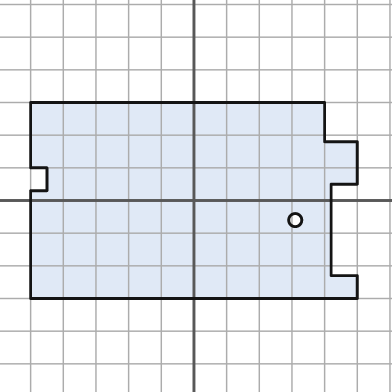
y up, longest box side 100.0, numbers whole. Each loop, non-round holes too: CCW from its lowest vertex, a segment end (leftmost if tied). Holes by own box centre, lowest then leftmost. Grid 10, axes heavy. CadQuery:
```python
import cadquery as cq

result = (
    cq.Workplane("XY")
    .moveTo(-50.0, -30.0)
    .lineTo(50.0, -30.0)
    .lineTo(50.0, -23.0)
    .lineTo(42.0, -23.0)
    .lineTo(42.0, 5.0)
    .lineTo(50.0, 5.0)
    .lineTo(50.0, 18.0)
    .lineTo(40.0, 18.0)
    .lineTo(40.0, 30.0)
    .lineTo(-50.0, 30.0)
    .lineTo(-50.0, 10.0)
    .lineTo(-45.0, 10.0)
    .lineTo(-45.0, 3.0)
    .lineTo(-50.0, 3.0)
    .close()
    .moveTo(31.0, -6.0)
    .circle(2.0)
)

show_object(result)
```